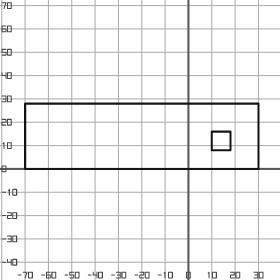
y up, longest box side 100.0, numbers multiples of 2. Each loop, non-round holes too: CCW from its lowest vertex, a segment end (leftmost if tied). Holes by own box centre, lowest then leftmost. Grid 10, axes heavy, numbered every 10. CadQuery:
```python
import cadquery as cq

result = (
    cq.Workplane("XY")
    .moveTo(-70.0, 0.0)
    .lineTo(30.0, 0.0)
    .lineTo(30.0, 28.0)
    .lineTo(-70.0, 28.0)
    .close()
    .moveTo(10.0, 8.0)
    .lineTo(18.0, 8.0)
    .lineTo(18.0, 16.0)
    .lineTo(10.0, 16.0)
    .close()
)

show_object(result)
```